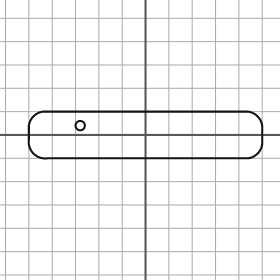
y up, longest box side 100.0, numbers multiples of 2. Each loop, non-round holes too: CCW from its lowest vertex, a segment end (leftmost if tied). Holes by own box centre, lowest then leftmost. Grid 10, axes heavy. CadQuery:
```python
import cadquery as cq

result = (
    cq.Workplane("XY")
    .moveTo(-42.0, -10.0)
    .lineTo(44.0, -10.0)
    .threePointArc((48.0, -8.0), (50.0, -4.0))
    .lineTo(50.0, 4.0)
    .threePointArc((48.0, 8.0), (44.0, 10.0))
    .lineTo(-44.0, 10.0)
    .threePointArc((-48.0, 8.0), (-50.0, 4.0))
    .lineTo(-50.0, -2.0)
    .threePointArc((-48.0, -8.0), (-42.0, -10.0))
    .close()
    .moveTo(-28.0, 4.0)
    .circle(2.0)
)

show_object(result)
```